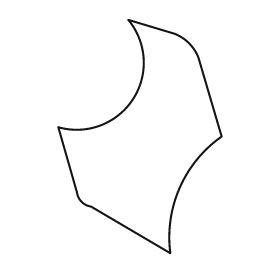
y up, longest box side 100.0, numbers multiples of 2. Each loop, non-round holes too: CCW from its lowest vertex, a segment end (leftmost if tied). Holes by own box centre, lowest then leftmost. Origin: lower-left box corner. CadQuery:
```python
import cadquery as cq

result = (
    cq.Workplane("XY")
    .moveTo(48.0, 0.0)
    .threePointArc((52.0, 28.0), (70.0, 50.0))
    .lineTo(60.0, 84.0)
    .threePointArc((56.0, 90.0), (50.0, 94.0))
    .lineTo(30.0, 100.0)
    .threePointArc((32.0, 66.0), (0.0, 54.0))
    .lineTo(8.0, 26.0)
    .threePointArc((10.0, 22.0), (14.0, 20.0))
    .close()
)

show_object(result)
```